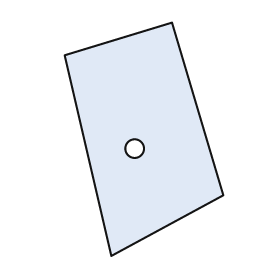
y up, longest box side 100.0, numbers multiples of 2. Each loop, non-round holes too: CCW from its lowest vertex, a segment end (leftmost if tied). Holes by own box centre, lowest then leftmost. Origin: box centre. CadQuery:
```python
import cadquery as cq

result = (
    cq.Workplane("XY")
    .moveTo(-14.0, -50.0)
    .lineTo(34.0, -24.0)
    .lineTo(12.0, 50.0)
    .lineTo(-34.0, 36.0)
    .close()
    .moveTo(-4.0, -4.0)
    .circle(4.0)
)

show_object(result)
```